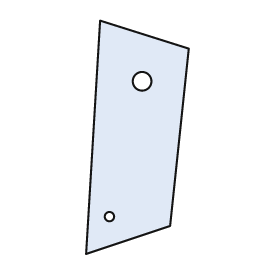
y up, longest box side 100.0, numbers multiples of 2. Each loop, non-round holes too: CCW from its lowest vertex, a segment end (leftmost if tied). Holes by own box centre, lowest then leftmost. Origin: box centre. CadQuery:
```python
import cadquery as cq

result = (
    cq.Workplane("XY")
    .moveTo(-22.0, -50.0)
    .lineTo(14.0, -38.0)
    .lineTo(22.0, 38.0)
    .lineTo(-16.0, 50.0)
    .close()
    .moveTo(-12.0, -34.0)
    .circle(2.0)
    .moveTo(2.0, 24.0)
    .circle(4.0)
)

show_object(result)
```